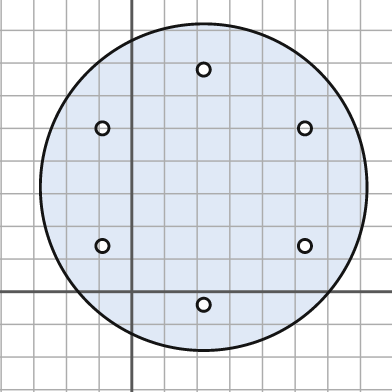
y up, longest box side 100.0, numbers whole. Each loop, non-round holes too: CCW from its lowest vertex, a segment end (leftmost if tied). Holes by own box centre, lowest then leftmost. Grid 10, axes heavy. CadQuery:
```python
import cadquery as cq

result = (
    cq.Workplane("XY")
    .moveTo(22.0, 32.0)
    .circle(50.0)
    .moveTo(22.0, -4.0)
    .circle(2.0)
    .moveTo(-9.0, 14.0)
    .circle(2.0)
    .moveTo(53.0, 14.0)
    .circle(2.0)
    .moveTo(-9.0, 50.0)
    .circle(2.0)
    .moveTo(53.0, 50.0)
    .circle(2.0)
    .moveTo(22.0, 68.0)
    .circle(2.0)
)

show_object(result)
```